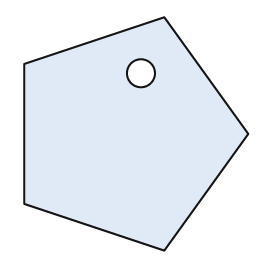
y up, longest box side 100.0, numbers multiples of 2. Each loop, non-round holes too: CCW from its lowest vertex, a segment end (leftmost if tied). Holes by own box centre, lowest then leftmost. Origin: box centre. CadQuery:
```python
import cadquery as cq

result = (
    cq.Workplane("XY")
    .moveTo(12.0, -50.0)
    .lineTo(48.0, 0.0)
    .lineTo(12.0, 50.0)
    .lineTo(-48.0, 30.0)
    .lineTo(-48.0, -30.0)
    .close()
    .moveTo(2.0, 26.0)
    .circle(6.0)
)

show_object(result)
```